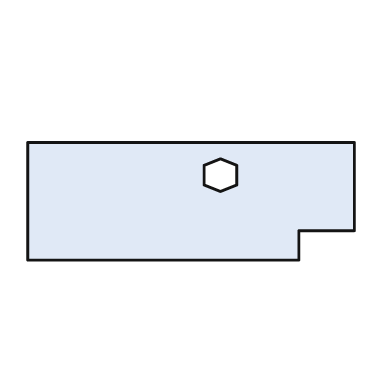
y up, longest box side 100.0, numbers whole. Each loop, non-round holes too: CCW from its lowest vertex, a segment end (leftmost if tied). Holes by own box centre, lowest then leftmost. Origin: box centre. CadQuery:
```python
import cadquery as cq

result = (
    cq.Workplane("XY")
    .moveTo(-50.0, -18.0)
    .lineTo(33.0, -18.0)
    .lineTo(33.0, -9.0)
    .lineTo(50.0, -9.0)
    .lineTo(50.0, 18.0)
    .lineTo(-50.0, 18.0)
    .close()
    .moveTo(9.0, 3.0)
    .lineTo(14.0, 5.0)
    .lineTo(14.0, 11.0)
    .lineTo(9.0, 13.0)
    .lineTo(4.0, 11.0)
    .lineTo(4.0, 5.0)
    .close()
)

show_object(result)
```